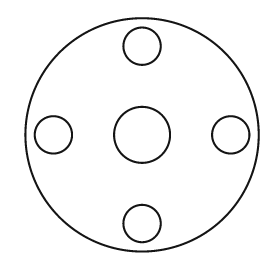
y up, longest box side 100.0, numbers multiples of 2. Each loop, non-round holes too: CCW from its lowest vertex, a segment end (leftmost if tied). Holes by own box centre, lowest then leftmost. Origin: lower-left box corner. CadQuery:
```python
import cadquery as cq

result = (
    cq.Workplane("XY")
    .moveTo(50.0, 50.0)
    .circle(50.0)
    .moveTo(50.0, 12.0)
    .circle(8.0)
    .moveTo(12.0, 50.0)
    .circle(8.0)
    .moveTo(50.0, 50.0)
    .circle(12.0)
    .moveTo(88.0, 50.0)
    .circle(8.0)
    .moveTo(50.0, 88.0)
    .circle(8.0)
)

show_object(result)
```